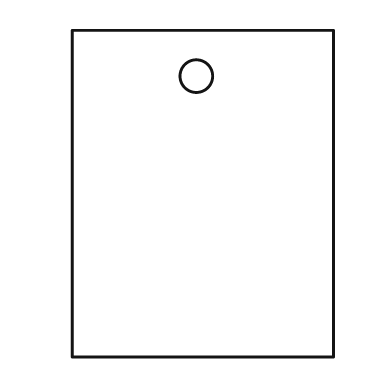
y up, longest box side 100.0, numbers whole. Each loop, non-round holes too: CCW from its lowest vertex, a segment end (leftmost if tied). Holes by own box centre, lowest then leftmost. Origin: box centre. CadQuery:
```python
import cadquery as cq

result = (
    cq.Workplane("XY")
    .moveTo(-40.0, -50.0)
    .lineTo(40.0, -50.0)
    .lineTo(40.0, 50.0)
    .lineTo(-40.0, 50.0)
    .close()
    .moveTo(-2.0, 36.0)
    .circle(5.0)
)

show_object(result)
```